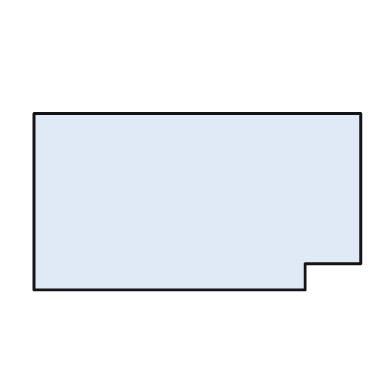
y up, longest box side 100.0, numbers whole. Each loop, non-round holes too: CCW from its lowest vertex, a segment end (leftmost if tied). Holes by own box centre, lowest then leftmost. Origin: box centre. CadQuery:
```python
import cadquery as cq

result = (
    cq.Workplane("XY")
    .moveTo(-50.0, -27.0)
    .lineTo(33.0, -27.0)
    .lineTo(33.0, -19.0)
    .lineTo(50.0, -19.0)
    .lineTo(50.0, 27.0)
    .lineTo(-50.0, 27.0)
    .close()
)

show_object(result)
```